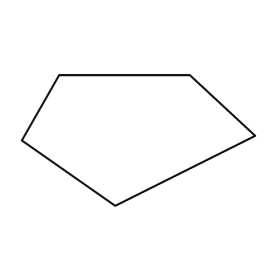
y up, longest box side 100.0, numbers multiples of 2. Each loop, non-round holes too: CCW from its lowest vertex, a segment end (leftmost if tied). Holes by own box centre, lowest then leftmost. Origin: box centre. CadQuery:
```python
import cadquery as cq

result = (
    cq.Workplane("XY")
    .moveTo(-10.0, -28.0)
    .lineTo(50.0, 2.0)
    .lineTo(22.0, 28.0)
    .lineTo(-34.0, 28.0)
    .lineTo(-50.0, 0.0)
    .close()
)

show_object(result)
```